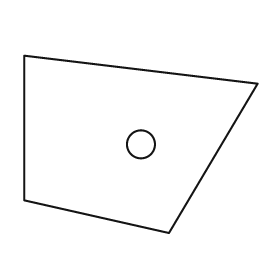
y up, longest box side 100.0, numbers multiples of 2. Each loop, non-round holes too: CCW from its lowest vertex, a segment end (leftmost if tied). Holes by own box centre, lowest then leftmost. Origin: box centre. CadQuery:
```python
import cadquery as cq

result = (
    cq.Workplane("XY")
    .moveTo(12.0, -38.0)
    .lineTo(50.0, 26.0)
    .lineTo(-50.0, 38.0)
    .lineTo(-50.0, -24.0)
    .close()
    .moveTo(0.0, 0.0)
    .circle(6.0)
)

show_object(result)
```